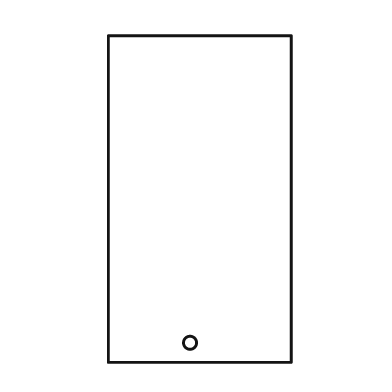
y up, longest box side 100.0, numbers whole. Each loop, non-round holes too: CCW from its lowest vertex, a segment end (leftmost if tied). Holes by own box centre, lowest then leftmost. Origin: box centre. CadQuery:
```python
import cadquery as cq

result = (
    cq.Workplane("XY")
    .moveTo(-28.0, -50.0)
    .lineTo(28.0, -50.0)
    .lineTo(28.0, 50.0)
    .lineTo(-28.0, 50.0)
    .close()
    .moveTo(-3.0, -44.0)
    .circle(2.0)
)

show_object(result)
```